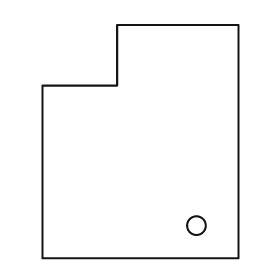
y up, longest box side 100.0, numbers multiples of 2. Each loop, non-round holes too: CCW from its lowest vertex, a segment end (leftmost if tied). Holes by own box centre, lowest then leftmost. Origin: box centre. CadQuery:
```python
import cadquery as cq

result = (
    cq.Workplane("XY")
    .moveTo(-42.0, -50.0)
    .lineTo(42.0, -50.0)
    .lineTo(42.0, 50.0)
    .lineTo(-10.0, 50.0)
    .lineTo(-10.0, 24.0)
    .lineTo(-42.0, 24.0)
    .close()
    .moveTo(24.0, -36.0)
    .circle(4.0)
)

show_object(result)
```